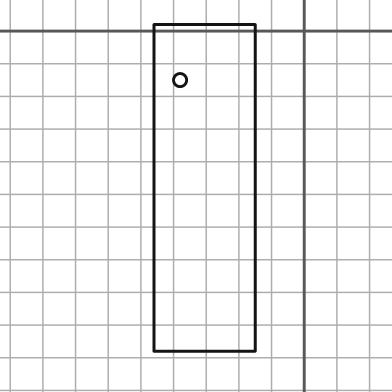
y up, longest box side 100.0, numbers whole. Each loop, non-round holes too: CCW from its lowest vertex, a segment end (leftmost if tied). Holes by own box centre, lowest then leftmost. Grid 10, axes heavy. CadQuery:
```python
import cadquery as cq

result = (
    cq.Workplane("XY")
    .moveTo(-46.0, -98.0)
    .lineTo(-15.0, -98.0)
    .lineTo(-15.0, 2.0)
    .lineTo(-46.0, 2.0)
    .close()
    .moveTo(-38.0, -15.0)
    .circle(2.0)
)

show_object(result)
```